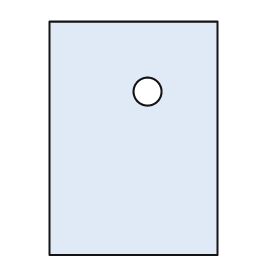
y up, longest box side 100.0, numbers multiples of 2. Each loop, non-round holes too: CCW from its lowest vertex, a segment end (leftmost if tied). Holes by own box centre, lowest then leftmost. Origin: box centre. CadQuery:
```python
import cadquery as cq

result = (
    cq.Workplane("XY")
    .moveTo(-36.0, -50.0)
    .lineTo(36.0, -50.0)
    .lineTo(36.0, 50.0)
    .lineTo(-36.0, 50.0)
    .close()
    .moveTo(6.0, 20.0)
    .circle(6.0)
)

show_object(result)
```